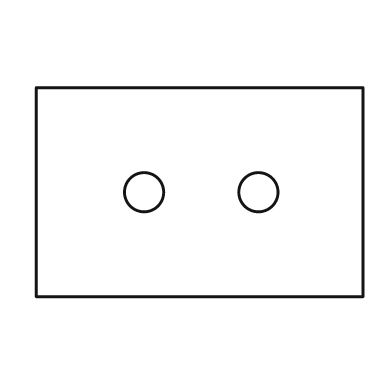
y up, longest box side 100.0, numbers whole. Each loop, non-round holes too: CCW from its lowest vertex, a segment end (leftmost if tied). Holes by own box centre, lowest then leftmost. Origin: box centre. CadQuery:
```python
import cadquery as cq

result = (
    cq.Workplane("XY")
    .moveTo(-50.0, -32.0)
    .lineTo(50.0, -32.0)
    .lineTo(50.0, 32.0)
    .lineTo(-50.0, 32.0)
    .close()
    .moveTo(-17.0, 0.0)
    .circle(6.0)
    .moveTo(18.0, 0.0)
    .circle(6.0)
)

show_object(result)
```